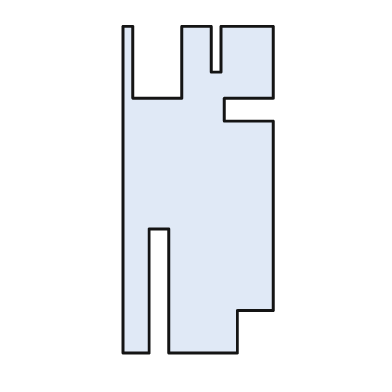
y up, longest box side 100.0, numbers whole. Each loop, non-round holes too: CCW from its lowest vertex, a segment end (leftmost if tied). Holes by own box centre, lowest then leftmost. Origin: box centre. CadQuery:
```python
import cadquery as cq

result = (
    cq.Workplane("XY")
    .moveTo(-23.0, -50.0)
    .lineTo(-15.0, -50.0)
    .lineTo(-15.0, -12.0)
    .lineTo(-9.0, -12.0)
    .lineTo(-9.0, -50.0)
    .lineTo(12.0, -50.0)
    .lineTo(12.0, -37.0)
    .lineTo(23.0, -37.0)
    .lineTo(23.0, 21.0)
    .lineTo(8.0, 21.0)
    .lineTo(8.0, 28.0)
    .lineTo(23.0, 28.0)
    .lineTo(23.0, 50.0)
    .lineTo(7.0, 50.0)
    .lineTo(7.0, 36.0)
    .lineTo(4.0, 36.0)
    .lineTo(4.0, 50.0)
    .lineTo(-5.0, 50.0)
    .lineTo(-5.0, 28.0)
    .lineTo(-20.0, 28.0)
    .lineTo(-20.0, 50.0)
    .lineTo(-23.0, 50.0)
    .close()
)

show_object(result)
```